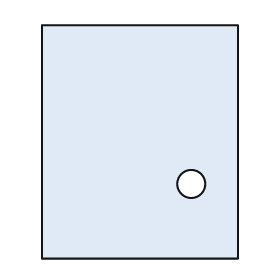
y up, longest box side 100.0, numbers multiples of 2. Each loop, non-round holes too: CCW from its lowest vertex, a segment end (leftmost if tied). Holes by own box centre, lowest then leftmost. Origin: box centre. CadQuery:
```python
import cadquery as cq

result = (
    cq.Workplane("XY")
    .moveTo(-42.0, -50.0)
    .lineTo(42.0, -50.0)
    .lineTo(42.0, 50.0)
    .lineTo(-42.0, 50.0)
    .close()
    .moveTo(22.0, -18.0)
    .circle(6.0)
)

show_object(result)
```